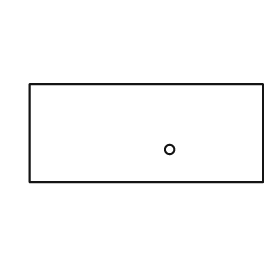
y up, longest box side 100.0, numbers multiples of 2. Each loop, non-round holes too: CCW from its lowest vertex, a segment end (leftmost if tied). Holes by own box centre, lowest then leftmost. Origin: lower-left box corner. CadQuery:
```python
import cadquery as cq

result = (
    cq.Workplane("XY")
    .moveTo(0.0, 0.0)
    .lineTo(100.0, 0.0)
    .lineTo(100.0, 42.0)
    .lineTo(0.0, 42.0)
    .close()
    .moveTo(60.0, 14.0)
    .circle(2.0)
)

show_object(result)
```